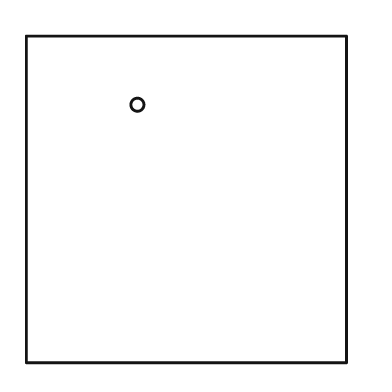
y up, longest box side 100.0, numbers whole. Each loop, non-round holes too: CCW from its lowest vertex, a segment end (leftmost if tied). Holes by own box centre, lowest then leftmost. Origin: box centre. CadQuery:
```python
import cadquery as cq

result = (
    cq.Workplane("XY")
    .moveTo(-49.0, -50.0)
    .lineTo(49.0, -50.0)
    .lineTo(49.0, 50.0)
    .lineTo(-49.0, 50.0)
    .close()
    .moveTo(-15.0, 29.0)
    .circle(2.0)
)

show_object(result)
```